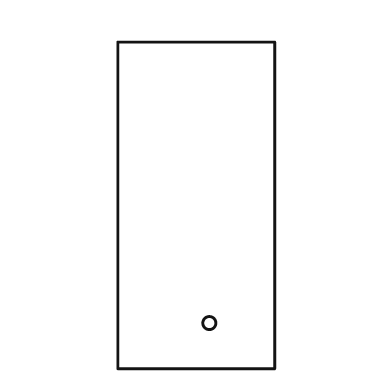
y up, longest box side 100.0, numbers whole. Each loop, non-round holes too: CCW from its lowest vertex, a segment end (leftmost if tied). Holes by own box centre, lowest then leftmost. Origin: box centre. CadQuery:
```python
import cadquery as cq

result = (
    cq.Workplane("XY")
    .moveTo(-24.0, -50.0)
    .lineTo(24.0, -50.0)
    .lineTo(24.0, 50.0)
    .lineTo(-24.0, 50.0)
    .close()
    .moveTo(4.0, -36.0)
    .circle(2.0)
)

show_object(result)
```